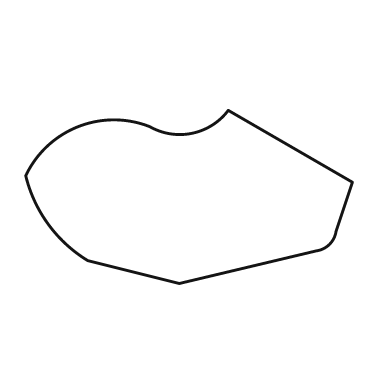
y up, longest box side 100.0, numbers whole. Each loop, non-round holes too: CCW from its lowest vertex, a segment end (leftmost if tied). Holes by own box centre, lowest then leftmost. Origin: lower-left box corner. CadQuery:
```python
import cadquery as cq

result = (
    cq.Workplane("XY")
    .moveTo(47.0, 0.0)
    .lineTo(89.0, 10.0)
    .threePointArc((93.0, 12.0), (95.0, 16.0))
    .lineTo(100.0, 31.0)
    .lineTo(62.0, 53.0)
    .threePointArc((51.0, 46.0), (38.0, 48.0))
    .threePointArc((16.0, 48.0), (0.0, 33.0))
    .threePointArc((7.0, 18.0), (19.0, 7.0))
    .close()
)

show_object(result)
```